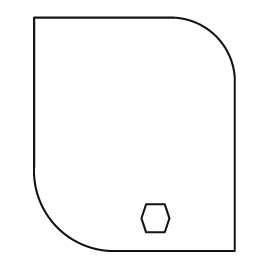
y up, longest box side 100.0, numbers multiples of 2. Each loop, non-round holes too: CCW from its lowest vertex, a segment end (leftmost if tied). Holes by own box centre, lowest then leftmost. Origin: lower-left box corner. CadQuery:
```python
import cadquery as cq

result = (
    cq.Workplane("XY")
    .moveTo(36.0, 0.0)
    .lineTo(86.0, 0.0)
    .lineTo(86.0, 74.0)
    .threePointArc((78.0, 92.0), (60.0, 100.0))
    .lineTo(0.0, 100.0)
    .lineTo(0.0, 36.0)
    .threePointArc((10.0, 10.0), (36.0, 0.0))
    .close()
    .moveTo(48.0, 8.0)
    .lineTo(56.0, 8.0)
    .lineTo(58.0, 14.0)
    .lineTo(56.0, 20.0)
    .lineTo(48.0, 20.0)
    .lineTo(46.0, 14.0)
    .close()
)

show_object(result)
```